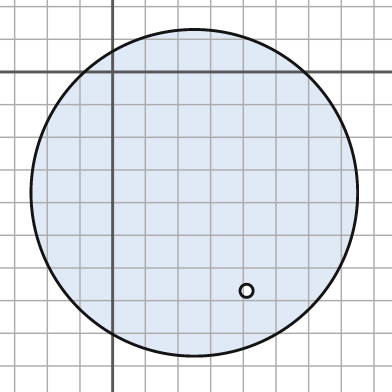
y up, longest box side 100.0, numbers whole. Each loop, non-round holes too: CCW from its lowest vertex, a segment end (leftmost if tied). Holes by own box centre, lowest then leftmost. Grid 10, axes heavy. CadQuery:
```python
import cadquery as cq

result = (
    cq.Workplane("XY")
    .moveTo(25.0, -37.0)
    .circle(50.0)
    .moveTo(41.0, -67.0)
    .circle(2.0)
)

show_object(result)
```